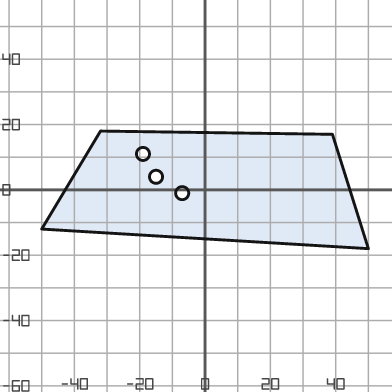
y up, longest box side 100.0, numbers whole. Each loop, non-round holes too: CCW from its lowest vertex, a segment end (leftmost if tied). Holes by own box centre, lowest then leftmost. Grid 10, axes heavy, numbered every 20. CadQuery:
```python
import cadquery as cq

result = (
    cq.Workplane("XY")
    .moveTo(50.0, -18.0)
    .lineTo(39.0, 17.0)
    .lineTo(-32.0, 18.0)
    .lineTo(-50.0, -12.0)
    .close()
    .moveTo(-7.0, -1.0)
    .circle(2.0)
    .moveTo(-15.0, 4.0)
    .circle(2.0)
    .moveTo(-19.0, 11.0)
    .circle(2.0)
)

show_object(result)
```